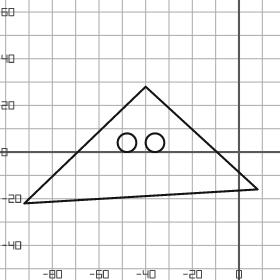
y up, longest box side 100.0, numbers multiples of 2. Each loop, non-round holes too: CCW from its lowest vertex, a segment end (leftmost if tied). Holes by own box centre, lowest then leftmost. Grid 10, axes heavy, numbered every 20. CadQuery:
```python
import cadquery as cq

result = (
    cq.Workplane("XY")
    .moveTo(-92.0, -22.0)
    .lineTo(8.0, -16.0)
    .lineTo(-40.0, 28.0)
    .close()
    .moveTo(-48.0, 4.0)
    .circle(4.0)
    .moveTo(-36.0, 4.0)
    .circle(4.0)
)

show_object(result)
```